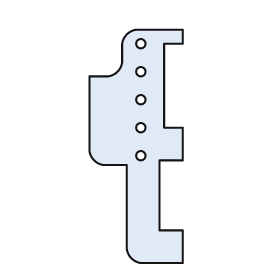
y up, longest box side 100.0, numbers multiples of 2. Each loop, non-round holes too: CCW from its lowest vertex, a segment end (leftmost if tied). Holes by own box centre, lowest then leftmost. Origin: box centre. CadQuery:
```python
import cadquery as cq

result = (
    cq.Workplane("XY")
    .moveTo(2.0, -50.0)
    .lineTo(20.0, -50.0)
    .lineTo(20.0, -36.0)
    .lineTo(10.0, -36.0)
    .lineTo(10.0, -6.0)
    .lineTo(20.0, -6.0)
    .lineTo(20.0, 8.0)
    .lineTo(12.0, 8.0)
    .lineTo(12.0, 44.0)
    .lineTo(20.0, 44.0)
    .lineTo(20.0, 50.0)
    .lineTo(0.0, 50.0)
    .threePointArc((-4.0, 48.0), (-6.0, 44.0))
    .lineTo(-6.0, 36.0)
    .threePointArc((-8.0, 32.0), (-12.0, 30.0))
    .lineTo(-20.0, 30.0)
    .lineTo(-20.0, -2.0)
    .threePointArc((-18.0, -6.0), (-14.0, -8.0))
    .lineTo(-4.0, -8.0)
    .lineTo(-4.0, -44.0)
    .threePointArc((-2.0, -48.0), (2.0, -50.0))
    .close()
    .moveTo(2.0, -4.0)
    .circle(2.0)
    .moveTo(2.0, 8.0)
    .circle(2.0)
    .moveTo(2.0, 20.0)
    .circle(2.0)
    .moveTo(2.0, 32.0)
    .circle(2.0)
    .moveTo(2.0, 44.0)
    .circle(2.0)
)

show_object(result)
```